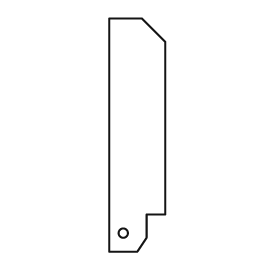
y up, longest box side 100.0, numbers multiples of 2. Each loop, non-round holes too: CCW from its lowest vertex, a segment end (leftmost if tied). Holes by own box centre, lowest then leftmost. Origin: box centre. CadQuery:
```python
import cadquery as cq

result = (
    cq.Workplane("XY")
    .moveTo(-12.0, -50.0)
    .lineTo(0.0, -50.0)
    .lineTo(4.0, -44.0)
    .lineTo(4.0, -34.0)
    .lineTo(12.0, -34.0)
    .lineTo(12.0, 40.0)
    .lineTo(2.0, 50.0)
    .lineTo(-12.0, 50.0)
    .close()
    .moveTo(-6.0, -42.0)
    .circle(2.0)
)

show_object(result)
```